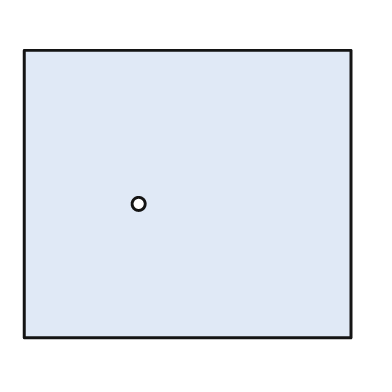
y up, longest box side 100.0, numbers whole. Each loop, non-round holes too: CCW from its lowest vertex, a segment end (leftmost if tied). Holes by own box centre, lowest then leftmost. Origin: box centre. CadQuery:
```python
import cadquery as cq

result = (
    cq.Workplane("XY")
    .moveTo(-50.0, -44.0)
    .lineTo(50.0, -44.0)
    .lineTo(50.0, 44.0)
    .lineTo(-50.0, 44.0)
    .close()
    .moveTo(-15.0, -3.0)
    .circle(2.0)
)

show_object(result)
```